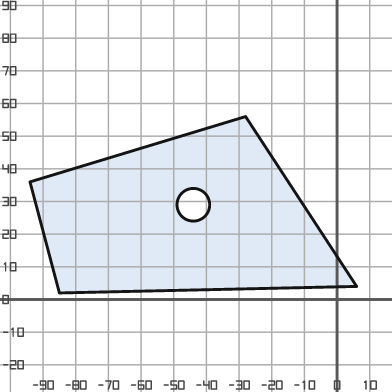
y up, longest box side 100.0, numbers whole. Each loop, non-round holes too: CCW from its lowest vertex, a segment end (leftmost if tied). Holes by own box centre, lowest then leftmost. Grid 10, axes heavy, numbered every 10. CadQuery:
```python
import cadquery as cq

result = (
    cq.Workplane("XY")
    .moveTo(-85.0, 2.0)
    .lineTo(6.0, 4.0)
    .lineTo(-28.0, 56.0)
    .lineTo(-94.0, 36.0)
    .close()
    .moveTo(-44.0, 29.0)
    .circle(5.0)
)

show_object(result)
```